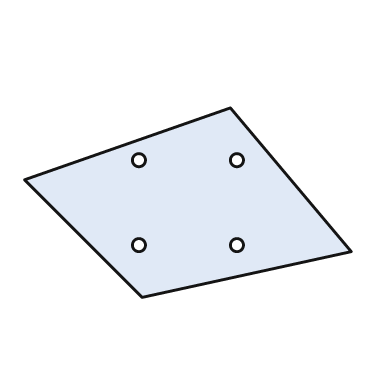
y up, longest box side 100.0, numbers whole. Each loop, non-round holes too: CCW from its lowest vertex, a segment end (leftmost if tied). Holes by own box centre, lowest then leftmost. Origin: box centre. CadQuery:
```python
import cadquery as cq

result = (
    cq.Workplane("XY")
    .moveTo(-14.0, -29.0)
    .lineTo(50.0, -15.0)
    .lineTo(13.0, 29.0)
    .lineTo(-50.0, 7.0)
    .close()
    .moveTo(-15.0, -13.0)
    .circle(2.0)
    .moveTo(15.0, -13.0)
    .circle(2.0)
    .moveTo(-15.0, 13.0)
    .circle(2.0)
    .moveTo(15.0, 13.0)
    .circle(2.0)
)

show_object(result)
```